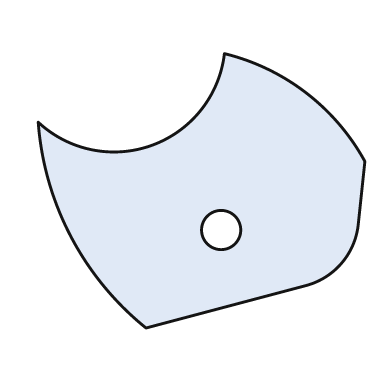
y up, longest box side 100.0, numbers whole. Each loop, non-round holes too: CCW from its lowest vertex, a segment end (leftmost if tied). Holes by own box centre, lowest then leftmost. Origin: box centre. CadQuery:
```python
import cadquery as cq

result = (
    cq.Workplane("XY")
    .moveTo(-17.0, -42.0)
    .lineTo(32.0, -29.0)
    .threePointArc((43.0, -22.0), (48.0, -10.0))
    .lineTo(50.0, 9.0)
    .threePointArc((32.0, 30.0), (7.0, 42.0))
    .threePointArc((-15.0, 14.0), (-50.0, 21.0))
    .threePointArc((-40.0, -14.0), (-17.0, -42.0))
    .close()
    .moveTo(6.0, -12.0)
    .circle(6.0)
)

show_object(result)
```